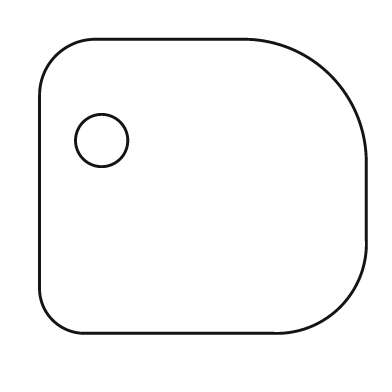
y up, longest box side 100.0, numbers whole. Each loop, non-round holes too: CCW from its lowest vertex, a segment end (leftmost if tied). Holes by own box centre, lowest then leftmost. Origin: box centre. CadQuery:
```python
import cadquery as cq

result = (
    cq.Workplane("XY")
    .moveTo(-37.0, -45.0)
    .lineTo(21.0, -45.0)
    .threePointArc((42.0, -37.0), (50.0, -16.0))
    .lineTo(50.0, 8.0)
    .threePointArc((39.0, 34.0), (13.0, 45.0))
    .lineTo(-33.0, 45.0)
    .threePointArc((-45.0, 40.0), (-50.0, 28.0))
    .lineTo(-50.0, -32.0)
    .threePointArc((-46.0, -41.0), (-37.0, -45.0))
    .close()
    .moveTo(-31.0, 14.0)
    .circle(8.0)
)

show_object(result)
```